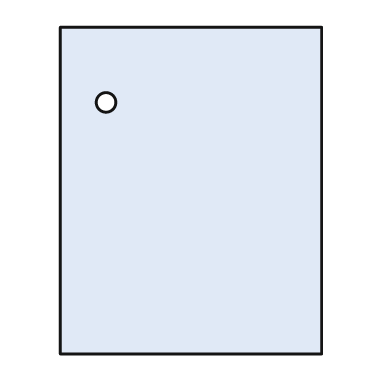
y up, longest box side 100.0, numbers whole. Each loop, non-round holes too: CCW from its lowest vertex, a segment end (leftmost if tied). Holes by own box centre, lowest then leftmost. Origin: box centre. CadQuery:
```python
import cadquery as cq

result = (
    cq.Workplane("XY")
    .moveTo(-40.0, -50.0)
    .lineTo(40.0, -50.0)
    .lineTo(40.0, 50.0)
    .lineTo(-40.0, 50.0)
    .close()
    .moveTo(-26.0, 27.0)
    .circle(3.0)
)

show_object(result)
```